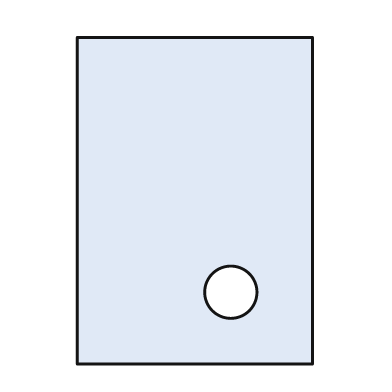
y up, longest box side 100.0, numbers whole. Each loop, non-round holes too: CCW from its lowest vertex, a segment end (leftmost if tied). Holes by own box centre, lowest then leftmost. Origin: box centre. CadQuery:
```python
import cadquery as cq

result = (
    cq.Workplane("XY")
    .moveTo(-36.0, -50.0)
    .lineTo(36.0, -50.0)
    .lineTo(36.0, 50.0)
    .lineTo(-36.0, 50.0)
    .close()
    .moveTo(11.0, -28.0)
    .circle(8.0)
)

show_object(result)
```